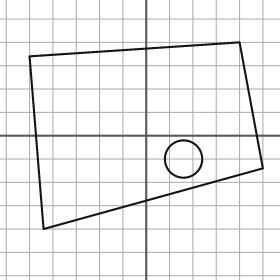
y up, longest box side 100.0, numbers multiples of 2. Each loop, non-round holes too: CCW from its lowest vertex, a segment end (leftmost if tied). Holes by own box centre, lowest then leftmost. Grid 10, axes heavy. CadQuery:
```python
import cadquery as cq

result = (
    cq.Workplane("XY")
    .moveTo(-44.0, -40.0)
    .lineTo(50.0, -14.0)
    .lineTo(40.0, 40.0)
    .lineTo(-50.0, 34.0)
    .close()
    .moveTo(16.0, -10.0)
    .circle(8.0)
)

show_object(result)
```